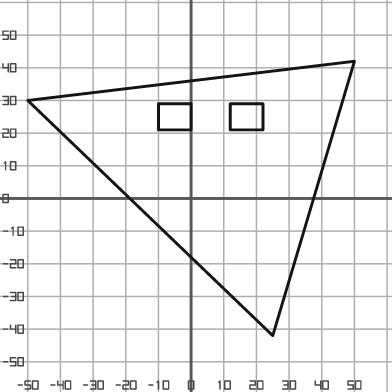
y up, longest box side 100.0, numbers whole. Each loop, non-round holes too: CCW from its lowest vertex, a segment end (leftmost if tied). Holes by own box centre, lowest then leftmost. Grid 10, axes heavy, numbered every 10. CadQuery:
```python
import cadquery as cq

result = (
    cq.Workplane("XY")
    .moveTo(25.0, -42.0)
    .lineTo(50.0, 42.0)
    .lineTo(-50.0, 30.0)
    .close()
    .moveTo(-10.0, 21.0)
    .lineTo(0.0, 21.0)
    .lineTo(0.0, 29.0)
    .lineTo(-10.0, 29.0)
    .close()
    .moveTo(12.0, 21.0)
    .lineTo(22.0, 21.0)
    .lineTo(22.0, 29.0)
    .lineTo(12.0, 29.0)
    .close()
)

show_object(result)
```